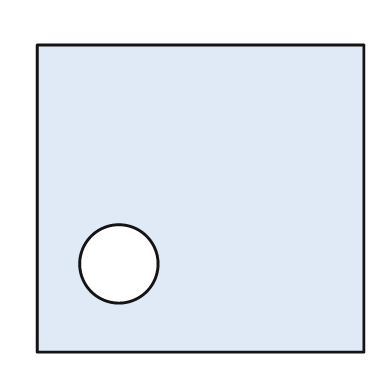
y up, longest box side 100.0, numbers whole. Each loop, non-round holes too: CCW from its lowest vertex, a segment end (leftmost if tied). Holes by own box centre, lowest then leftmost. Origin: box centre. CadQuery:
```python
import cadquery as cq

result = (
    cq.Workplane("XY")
    .moveTo(-50.0, -47.0)
    .lineTo(50.0, -47.0)
    .lineTo(50.0, 47.0)
    .lineTo(-50.0, 47.0)
    .close()
    .moveTo(-25.0, -20.0)
    .circle(12.0)
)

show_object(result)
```